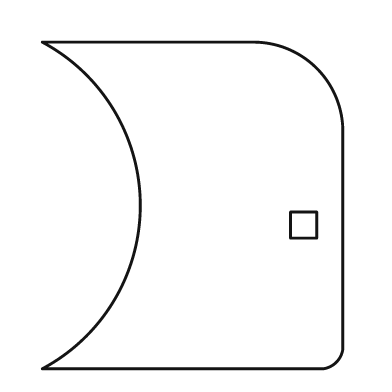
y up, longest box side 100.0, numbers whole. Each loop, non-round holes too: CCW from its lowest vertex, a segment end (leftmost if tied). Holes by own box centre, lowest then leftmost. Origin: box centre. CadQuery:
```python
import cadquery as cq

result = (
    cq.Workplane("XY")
    .moveTo(-46.0, -50.0)
    .lineTo(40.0, -50.0)
    .threePointArc((44.0, -48.0), (46.0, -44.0))
    .lineTo(46.0, 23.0)
    .threePointArc((38.0, 42.0), (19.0, 50.0))
    .lineTo(-46.0, 50.0)
    .threePointArc((-16.0, 0.0), (-46.0, -50.0))
    .close()
    .moveTo(30.0, -10.0)
    .lineTo(38.0, -10.0)
    .lineTo(38.0, -2.0)
    .lineTo(30.0, -2.0)
    .close()
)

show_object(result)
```